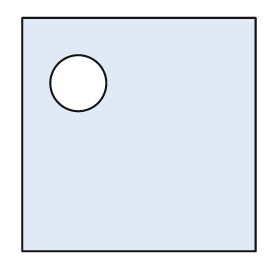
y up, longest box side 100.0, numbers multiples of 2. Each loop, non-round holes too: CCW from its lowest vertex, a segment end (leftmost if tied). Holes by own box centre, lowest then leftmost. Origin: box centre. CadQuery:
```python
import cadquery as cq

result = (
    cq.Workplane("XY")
    .moveTo(-50.0, -50.0)
    .lineTo(50.0, -50.0)
    .lineTo(50.0, 50.0)
    .lineTo(-50.0, 50.0)
    .close()
    .moveTo(-26.0, 22.0)
    .circle(12.0)
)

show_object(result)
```